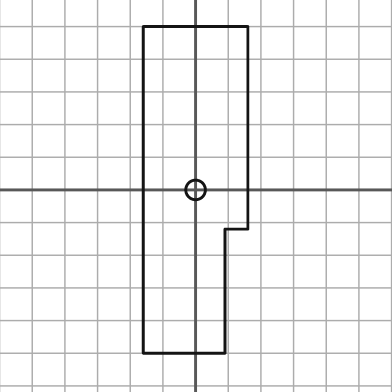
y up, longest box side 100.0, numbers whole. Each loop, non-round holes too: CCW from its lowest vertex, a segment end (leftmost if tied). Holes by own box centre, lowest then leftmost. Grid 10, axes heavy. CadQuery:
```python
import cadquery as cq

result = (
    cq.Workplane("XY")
    .moveTo(-16.0, -50.0)
    .lineTo(9.0, -50.0)
    .lineTo(9.0, -12.0)
    .lineTo(16.0, -12.0)
    .lineTo(16.0, 50.0)
    .lineTo(-16.0, 50.0)
    .close()
    .moveTo(0.0, 0.0)
    .circle(3.0)
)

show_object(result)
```